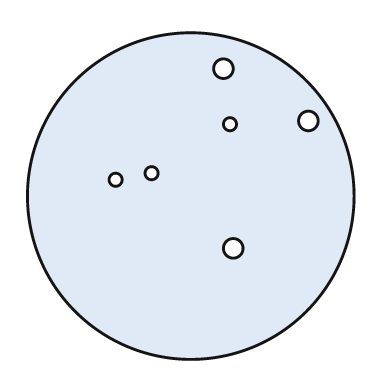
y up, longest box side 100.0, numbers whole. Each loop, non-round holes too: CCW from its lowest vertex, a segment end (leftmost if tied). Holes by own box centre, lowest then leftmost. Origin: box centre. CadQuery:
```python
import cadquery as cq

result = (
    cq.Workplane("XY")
    .moveTo(0.0, 0.0)
    .circle(50.0)
    .moveTo(13.0, -16.0)
    .circle(3.0)
    .moveTo(-23.0, 5.0)
    .circle(2.0)
    .moveTo(-12.0, 7.0)
    .circle(2.0)
    .moveTo(12.0, 22.0)
    .circle(2.0)
    .moveTo(36.0, 23.0)
    .circle(3.0)
    .moveTo(10.0, 39.0)
    .circle(3.0)
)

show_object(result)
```